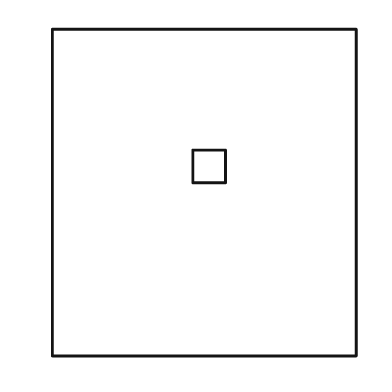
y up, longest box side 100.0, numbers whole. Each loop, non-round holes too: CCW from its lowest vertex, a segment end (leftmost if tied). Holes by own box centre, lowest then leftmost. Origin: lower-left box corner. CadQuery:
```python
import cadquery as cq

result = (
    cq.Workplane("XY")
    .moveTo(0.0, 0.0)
    .lineTo(93.0, 0.0)
    .lineTo(93.0, 100.0)
    .lineTo(0.0, 100.0)
    .close()
    .moveTo(43.0, 53.0)
    .lineTo(53.0, 53.0)
    .lineTo(53.0, 63.0)
    .lineTo(43.0, 63.0)
    .close()
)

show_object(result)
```